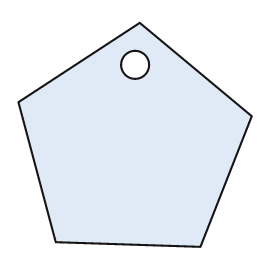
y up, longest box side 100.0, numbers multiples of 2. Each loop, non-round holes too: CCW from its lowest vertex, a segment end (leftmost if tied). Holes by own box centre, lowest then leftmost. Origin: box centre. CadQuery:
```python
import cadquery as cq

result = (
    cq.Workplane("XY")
    .moveTo(28.0, -48.0)
    .lineTo(50.0, 8.0)
    .lineTo(2.0, 48.0)
    .lineTo(-50.0, 14.0)
    .lineTo(-34.0, -46.0)
    .close()
    .moveTo(0.0, 30.0)
    .circle(6.0)
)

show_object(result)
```